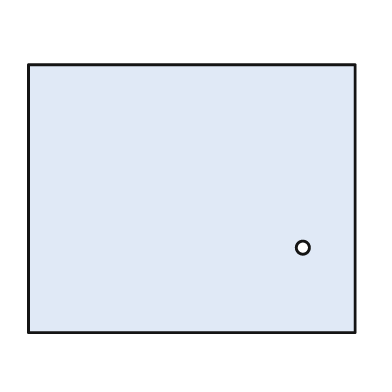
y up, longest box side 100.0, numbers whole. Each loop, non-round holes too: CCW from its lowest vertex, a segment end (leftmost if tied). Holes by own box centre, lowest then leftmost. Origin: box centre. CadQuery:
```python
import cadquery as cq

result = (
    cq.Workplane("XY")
    .moveTo(-50.0, -41.0)
    .lineTo(50.0, -41.0)
    .lineTo(50.0, 41.0)
    .lineTo(-50.0, 41.0)
    .close()
    .moveTo(34.0, -15.0)
    .circle(2.0)
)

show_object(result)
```